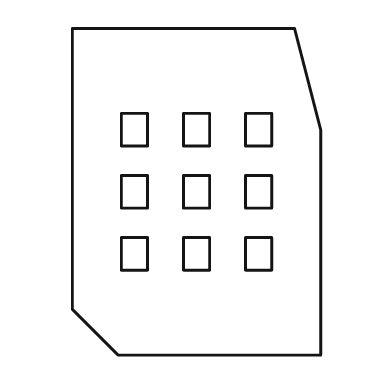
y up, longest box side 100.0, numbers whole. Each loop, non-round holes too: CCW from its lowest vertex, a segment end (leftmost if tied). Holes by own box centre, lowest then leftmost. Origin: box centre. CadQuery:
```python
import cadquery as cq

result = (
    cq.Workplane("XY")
    .moveTo(-24.0, -50.0)
    .lineTo(38.0, -50.0)
    .lineTo(38.0, 19.0)
    .lineTo(30.0, 50.0)
    .lineTo(-38.0, 50.0)
    .lineTo(-38.0, -36.0)
    .close()
    .moveTo(-23.0, -24.0)
    .lineTo(-15.0, -24.0)
    .lineTo(-15.0, -14.0)
    .lineTo(-23.0, -14.0)
    .close()
    .moveTo(-4.0, -24.0)
    .lineTo(4.0, -24.0)
    .lineTo(4.0, -14.0)
    .lineTo(-4.0, -14.0)
    .close()
    .moveTo(15.0, -24.0)
    .lineTo(23.0, -24.0)
    .lineTo(23.0, -14.0)
    .lineTo(15.0, -14.0)
    .close()
    .moveTo(-23.0, -5.0)
    .lineTo(-15.0, -5.0)
    .lineTo(-15.0, 5.0)
    .lineTo(-23.0, 5.0)
    .close()
    .moveTo(-4.0, -5.0)
    .lineTo(4.0, -5.0)
    .lineTo(4.0, 5.0)
    .lineTo(-4.0, 5.0)
    .close()
    .moveTo(15.0, -5.0)
    .lineTo(23.0, -5.0)
    .lineTo(23.0, 5.0)
    .lineTo(15.0, 5.0)
    .close()
    .moveTo(-23.0, 14.0)
    .lineTo(-15.0, 14.0)
    .lineTo(-15.0, 24.0)
    .lineTo(-23.0, 24.0)
    .close()
    .moveTo(-4.0, 14.0)
    .lineTo(4.0, 14.0)
    .lineTo(4.0, 24.0)
    .lineTo(-4.0, 24.0)
    .close()
    .moveTo(15.0, 14.0)
    .lineTo(23.0, 14.0)
    .lineTo(23.0, 24.0)
    .lineTo(15.0, 24.0)
    .close()
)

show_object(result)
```